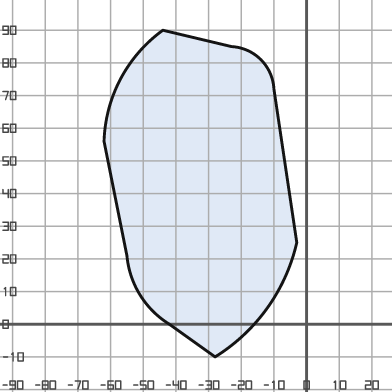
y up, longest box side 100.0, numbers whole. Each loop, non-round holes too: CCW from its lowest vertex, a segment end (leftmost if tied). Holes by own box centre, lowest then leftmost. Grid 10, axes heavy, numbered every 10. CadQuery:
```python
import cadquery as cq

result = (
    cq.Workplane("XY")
    .moveTo(-28.0, -10.0)
    .threePointArc((-12.0, 5.0), (-3.0, 25.0))
    .lineTo(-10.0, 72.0)
    .threePointArc((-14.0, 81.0), (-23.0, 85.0))
    .lineTo(-44.0, 90.0)
    .threePointArc((-57.0, 75.0), (-62.0, 56.0))
    .lineTo(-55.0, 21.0)
    .threePointArc((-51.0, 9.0), (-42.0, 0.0))
    .close()
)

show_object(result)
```